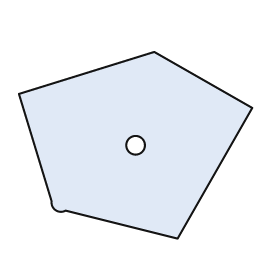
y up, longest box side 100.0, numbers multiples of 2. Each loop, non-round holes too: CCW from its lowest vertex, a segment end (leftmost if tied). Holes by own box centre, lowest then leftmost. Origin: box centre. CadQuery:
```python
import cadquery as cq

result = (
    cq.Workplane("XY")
    .moveTo(18.0, -40.0)
    .lineTo(50.0, 16.0)
    .lineTo(8.0, 40.0)
    .lineTo(-50.0, 22.0)
    .lineTo(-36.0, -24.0)
    .threePointArc((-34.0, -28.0), (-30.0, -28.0))
    .close()
    .moveTo(0.0, 0.0)
    .circle(4.0)
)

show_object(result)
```